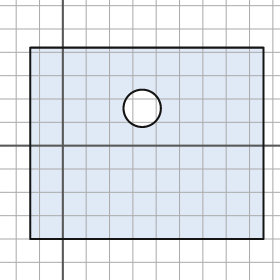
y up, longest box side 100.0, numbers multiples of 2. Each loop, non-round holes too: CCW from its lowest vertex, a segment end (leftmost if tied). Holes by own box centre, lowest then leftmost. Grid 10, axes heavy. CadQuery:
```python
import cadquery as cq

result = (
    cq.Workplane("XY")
    .moveTo(-14.0, -40.0)
    .lineTo(86.0, -40.0)
    .lineTo(86.0, 42.0)
    .lineTo(-14.0, 42.0)
    .close()
    .moveTo(34.0, 16.0)
    .circle(8.0)
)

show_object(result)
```